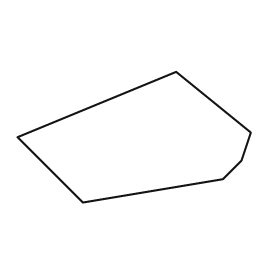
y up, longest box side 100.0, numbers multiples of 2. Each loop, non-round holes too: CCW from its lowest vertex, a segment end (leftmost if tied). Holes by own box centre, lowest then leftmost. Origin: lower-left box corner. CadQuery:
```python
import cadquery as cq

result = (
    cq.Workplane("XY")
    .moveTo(28.0, 0.0)
    .lineTo(88.0, 10.0)
    .lineTo(96.0, 18.0)
    .lineTo(100.0, 30.0)
    .lineTo(68.0, 56.0)
    .lineTo(0.0, 28.0)
    .close()
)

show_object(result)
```